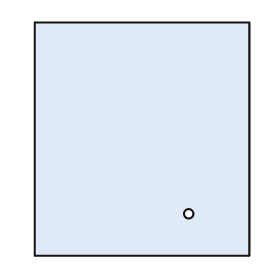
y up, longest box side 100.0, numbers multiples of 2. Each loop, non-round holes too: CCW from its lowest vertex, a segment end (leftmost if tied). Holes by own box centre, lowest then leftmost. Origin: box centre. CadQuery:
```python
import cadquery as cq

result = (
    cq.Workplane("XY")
    .moveTo(-46.0, -50.0)
    .lineTo(46.0, -50.0)
    .lineTo(46.0, 50.0)
    .lineTo(-46.0, 50.0)
    .close()
    .moveTo(20.0, -32.0)
    .circle(2.0)
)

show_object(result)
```